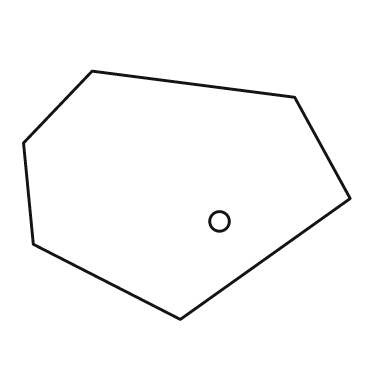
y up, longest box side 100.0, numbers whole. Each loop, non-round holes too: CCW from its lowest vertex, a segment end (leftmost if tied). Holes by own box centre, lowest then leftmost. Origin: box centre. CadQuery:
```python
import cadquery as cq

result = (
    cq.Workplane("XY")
    .moveTo(-2.0, -38.0)
    .lineTo(50.0, -1.0)
    .lineTo(33.0, 30.0)
    .lineTo(-29.0, 38.0)
    .lineTo(-50.0, 16.0)
    .lineTo(-47.0, -15.0)
    .close()
    .moveTo(10.0, -8.0)
    .circle(3.0)
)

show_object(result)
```